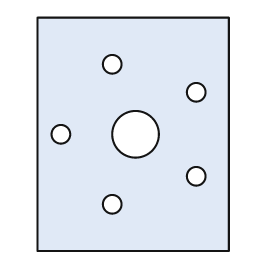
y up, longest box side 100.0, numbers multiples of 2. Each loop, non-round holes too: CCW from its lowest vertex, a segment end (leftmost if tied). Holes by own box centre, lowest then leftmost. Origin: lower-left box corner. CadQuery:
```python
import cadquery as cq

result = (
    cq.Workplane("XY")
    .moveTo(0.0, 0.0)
    .lineTo(82.0, 0.0)
    .lineTo(82.0, 100.0)
    .lineTo(0.0, 100.0)
    .close()
    .moveTo(32.0, 20.0)
    .circle(4.0)
    .moveTo(68.0, 32.0)
    .circle(4.0)
    .moveTo(10.0, 50.0)
    .circle(4.0)
    .moveTo(42.0, 50.0)
    .circle(10.0)
    .moveTo(68.0, 68.0)
    .circle(4.0)
    .moveTo(32.0, 80.0)
    .circle(4.0)
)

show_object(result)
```